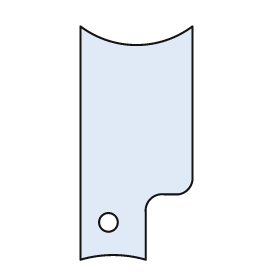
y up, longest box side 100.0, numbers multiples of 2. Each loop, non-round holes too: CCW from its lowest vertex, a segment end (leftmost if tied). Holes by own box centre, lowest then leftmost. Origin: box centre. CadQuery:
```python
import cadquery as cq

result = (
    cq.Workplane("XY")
    .moveTo(-24.0, -50.0)
    .threePointArc((-10.0, -48.0), (4.0, -50.0))
    .lineTo(4.0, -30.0)
    .threePointArc((6.0, -24.0), (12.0, -22.0))
    .lineTo(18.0, -22.0)
    .threePointArc((22.0, -20.0), (24.0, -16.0))
    .lineTo(24.0, 50.0)
    .threePointArc((0.0, 42.0), (-24.0, 50.0))
    .close()
    .moveTo(-12.0, -34.0)
    .circle(4.0)
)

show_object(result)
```